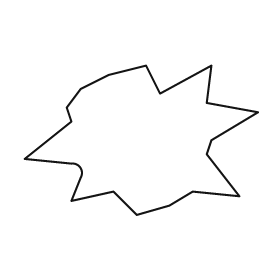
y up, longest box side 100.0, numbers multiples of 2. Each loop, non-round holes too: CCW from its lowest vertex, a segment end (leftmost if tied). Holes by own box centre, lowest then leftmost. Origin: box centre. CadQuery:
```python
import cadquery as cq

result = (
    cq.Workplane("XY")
    .moveTo(-2.0, -32.0)
    .lineTo(12.0, -28.0)
    .lineTo(22.0, -22.0)
    .lineTo(42.0, -24.0)
    .lineTo(28.0, -6.0)
    .lineTo(30.0, 0.0)
    .lineTo(50.0, 12.0)
    .lineTo(28.0, 16.0)
    .lineTo(30.0, 32.0)
    .lineTo(8.0, 20.0)
    .lineTo(2.0, 32.0)
    .lineTo(-14.0, 28.0)
    .lineTo(-26.0, 22.0)
    .lineTo(-32.0, 14.0)
    .lineTo(-30.0, 8.0)
    .lineTo(-50.0, -8.0)
    .lineTo(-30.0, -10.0)
    .threePointArc((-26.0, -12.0), (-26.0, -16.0))
    .lineTo(-30.0, -26.0)
    .lineTo(-12.0, -22.0)
    .close()
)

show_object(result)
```